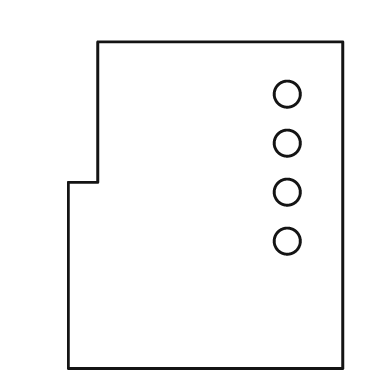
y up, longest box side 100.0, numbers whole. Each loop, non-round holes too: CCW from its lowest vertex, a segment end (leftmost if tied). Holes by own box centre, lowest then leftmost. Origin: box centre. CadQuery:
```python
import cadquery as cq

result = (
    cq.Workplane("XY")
    .moveTo(-42.0, -50.0)
    .lineTo(42.0, -50.0)
    .lineTo(42.0, 50.0)
    .lineTo(-33.0, 50.0)
    .lineTo(-33.0, 7.0)
    .lineTo(-42.0, 7.0)
    .close()
    .moveTo(25.0, -11.0)
    .circle(4.0)
    .moveTo(25.0, 4.0)
    .circle(4.0)
    .moveTo(25.0, 19.0)
    .circle(4.0)
    .moveTo(25.0, 34.0)
    .circle(4.0)
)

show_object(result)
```